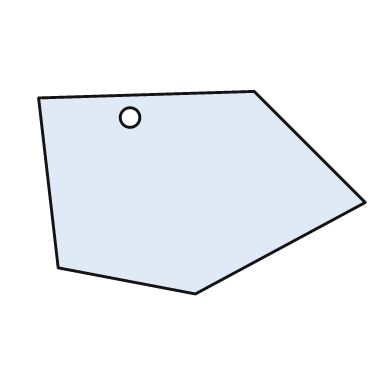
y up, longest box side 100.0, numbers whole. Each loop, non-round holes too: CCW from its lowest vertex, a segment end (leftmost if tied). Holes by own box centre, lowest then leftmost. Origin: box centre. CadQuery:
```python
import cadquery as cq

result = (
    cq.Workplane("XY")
    .moveTo(-2.0, -31.0)
    .lineTo(50.0, -3.0)
    .lineTo(16.0, 31.0)
    .lineTo(-50.0, 29.0)
    .lineTo(-44.0, -23.0)
    .close()
    .moveTo(-22.0, 23.0)
    .circle(3.0)
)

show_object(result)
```